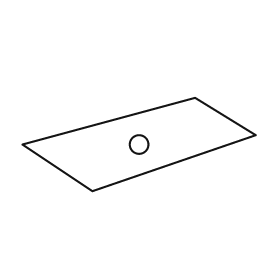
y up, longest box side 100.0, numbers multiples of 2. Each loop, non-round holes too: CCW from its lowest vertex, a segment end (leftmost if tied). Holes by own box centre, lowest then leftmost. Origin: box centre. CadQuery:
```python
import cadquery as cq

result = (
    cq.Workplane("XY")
    .moveTo(-20.0, -20.0)
    .lineTo(50.0, 4.0)
    .lineTo(24.0, 20.0)
    .lineTo(-50.0, 0.0)
    .close()
    .moveTo(0.0, 0.0)
    .circle(4.0)
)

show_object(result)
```